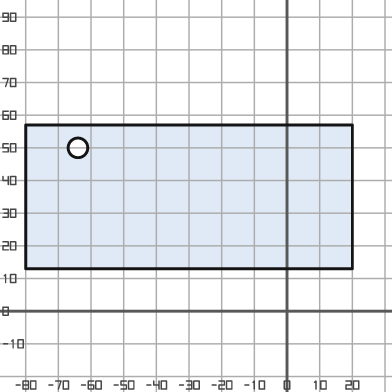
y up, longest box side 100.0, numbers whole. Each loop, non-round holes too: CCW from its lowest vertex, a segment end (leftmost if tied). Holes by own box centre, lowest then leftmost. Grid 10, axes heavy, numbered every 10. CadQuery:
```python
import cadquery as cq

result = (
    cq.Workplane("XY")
    .moveTo(-80.0, 13.0)
    .lineTo(20.0, 13.0)
    .lineTo(20.0, 57.0)
    .lineTo(-80.0, 57.0)
    .close()
    .moveTo(-64.0, 50.0)
    .circle(3.0)
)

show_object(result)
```